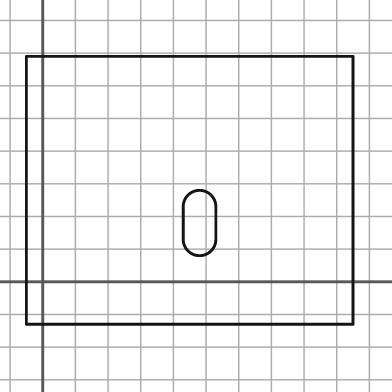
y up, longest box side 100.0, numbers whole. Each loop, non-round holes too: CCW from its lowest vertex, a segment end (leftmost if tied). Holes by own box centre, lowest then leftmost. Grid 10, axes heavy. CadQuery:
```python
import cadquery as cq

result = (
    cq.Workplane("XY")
    .moveTo(-5.0, -13.0)
    .lineTo(95.0, -13.0)
    .lineTo(95.0, 69.0)
    .lineTo(-5.0, 69.0)
    .close()
    .moveTo(43.0, 13.0)
    .threePointArc((48.0, 8.0), (53.0, 13.0))
    .lineTo(53.0, 23.0)
    .threePointArc((48.0, 28.0), (43.0, 23.0))
    .close()
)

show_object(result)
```